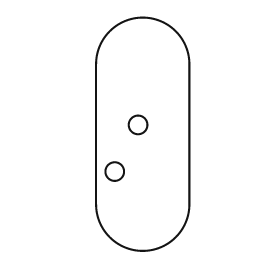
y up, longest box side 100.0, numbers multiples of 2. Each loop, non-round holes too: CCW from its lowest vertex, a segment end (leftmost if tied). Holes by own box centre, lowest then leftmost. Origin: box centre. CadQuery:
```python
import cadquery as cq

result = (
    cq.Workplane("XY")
    .moveTo(-20.0, -30.0)
    .threePointArc((0.0, -50.0), (20.0, -30.0))
    .lineTo(20.0, 30.0)
    .threePointArc((0.0, 50.0), (-20.0, 30.0))
    .close()
    .moveTo(-12.0, -16.0)
    .circle(4.0)
    .moveTo(-2.0, 4.0)
    .circle(4.0)
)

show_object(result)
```